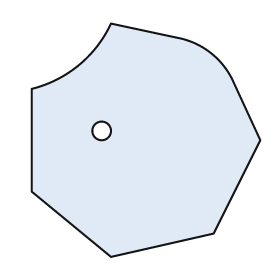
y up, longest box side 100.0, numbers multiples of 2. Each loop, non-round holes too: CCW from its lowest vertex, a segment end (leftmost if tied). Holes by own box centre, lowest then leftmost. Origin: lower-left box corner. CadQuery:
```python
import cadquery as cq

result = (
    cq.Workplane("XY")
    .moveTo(34.0, 0.0)
    .lineTo(78.0, 10.0)
    .lineTo(98.0, 50.0)
    .lineTo(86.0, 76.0)
    .threePointArc((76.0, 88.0), (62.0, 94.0))
    .lineTo(34.0, 100.0)
    .threePointArc((20.0, 82.0), (0.0, 72.0))
    .lineTo(0.0, 28.0)
    .close()
    .moveTo(30.0, 54.0)
    .circle(4.0)
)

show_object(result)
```